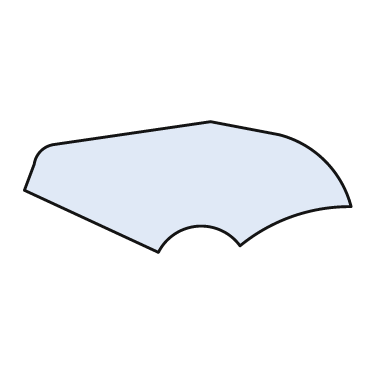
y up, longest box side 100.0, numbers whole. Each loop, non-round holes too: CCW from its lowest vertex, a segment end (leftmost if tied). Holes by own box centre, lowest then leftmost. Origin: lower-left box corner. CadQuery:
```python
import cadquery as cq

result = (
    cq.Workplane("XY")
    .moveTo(41.0, 0.0)
    .threePointArc((53.0, 8.0), (66.0, 2.0))
    .threePointArc((82.0, 11.0), (100.0, 14.0))
    .threePointArc((92.0, 28.0), (78.0, 36.0))
    .lineTo(57.0, 40.0)
    .lineTo(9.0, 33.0)
    .threePointArc((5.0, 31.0), (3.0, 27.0))
    .lineTo(0.0, 19.0)
    .close()
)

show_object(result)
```